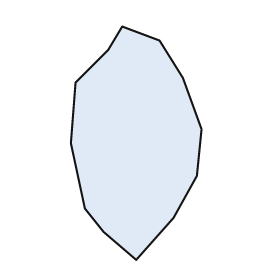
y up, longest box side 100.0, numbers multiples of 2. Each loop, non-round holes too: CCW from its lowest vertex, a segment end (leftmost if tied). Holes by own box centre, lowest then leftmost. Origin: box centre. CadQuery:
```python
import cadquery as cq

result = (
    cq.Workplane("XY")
    .moveTo(0.0, -50.0)
    .lineTo(16.0, -32.0)
    .lineTo(26.0, -14.0)
    .lineTo(28.0, 6.0)
    .lineTo(20.0, 28.0)
    .lineTo(10.0, 44.0)
    .lineTo(-6.0, 50.0)
    .lineTo(-12.0, 40.0)
    .lineTo(-26.0, 26.0)
    .lineTo(-28.0, 0.0)
    .lineTo(-22.0, -28.0)
    .lineTo(-14.0, -38.0)
    .close()
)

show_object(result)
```